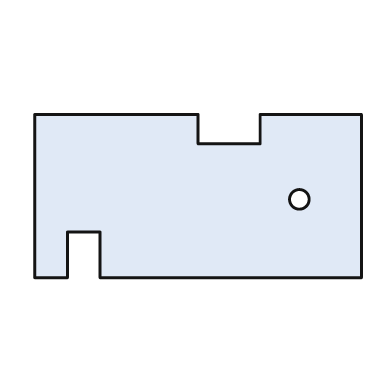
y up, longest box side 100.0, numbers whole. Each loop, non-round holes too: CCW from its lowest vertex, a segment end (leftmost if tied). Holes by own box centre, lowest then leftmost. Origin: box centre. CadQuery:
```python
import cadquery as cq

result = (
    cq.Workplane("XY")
    .moveTo(-50.0, -25.0)
    .lineTo(-40.0, -25.0)
    .lineTo(-40.0, -11.0)
    .lineTo(-30.0, -11.0)
    .lineTo(-30.0, -25.0)
    .lineTo(50.0, -25.0)
    .lineTo(50.0, 25.0)
    .lineTo(19.0, 25.0)
    .lineTo(19.0, 16.0)
    .lineTo(0.0, 16.0)
    .lineTo(0.0, 25.0)
    .lineTo(-50.0, 25.0)
    .close()
    .moveTo(31.0, -1.0)
    .circle(3.0)
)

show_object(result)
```